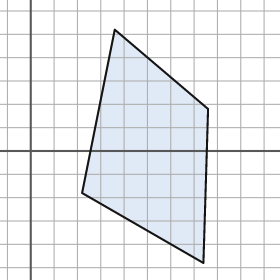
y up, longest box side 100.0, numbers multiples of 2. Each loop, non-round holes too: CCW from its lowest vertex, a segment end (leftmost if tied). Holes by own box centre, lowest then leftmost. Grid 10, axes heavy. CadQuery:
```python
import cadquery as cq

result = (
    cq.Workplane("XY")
    .moveTo(74.0, -48.0)
    .lineTo(76.0, 18.0)
    .lineTo(36.0, 52.0)
    .lineTo(22.0, -18.0)
    .close()
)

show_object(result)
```